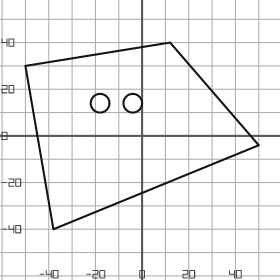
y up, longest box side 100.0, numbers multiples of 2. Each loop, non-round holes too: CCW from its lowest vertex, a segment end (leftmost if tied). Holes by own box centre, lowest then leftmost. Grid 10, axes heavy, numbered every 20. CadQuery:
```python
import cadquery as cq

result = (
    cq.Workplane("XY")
    .moveTo(-38.0, -40.0)
    .lineTo(50.0, -4.0)
    .lineTo(12.0, 40.0)
    .lineTo(-50.0, 30.0)
    .close()
    .moveTo(-18.0, 14.0)
    .circle(4.0)
    .moveTo(-4.0, 14.0)
    .circle(4.0)
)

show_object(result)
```